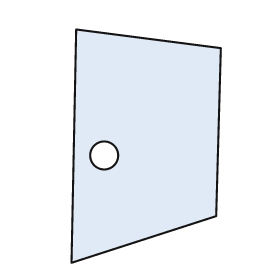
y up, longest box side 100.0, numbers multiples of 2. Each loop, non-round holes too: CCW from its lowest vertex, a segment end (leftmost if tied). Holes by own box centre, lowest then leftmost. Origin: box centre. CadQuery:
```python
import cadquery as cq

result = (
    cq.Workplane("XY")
    .moveTo(-32.0, -50.0)
    .lineTo(30.0, -30.0)
    .lineTo(32.0, 42.0)
    .lineTo(-30.0, 50.0)
    .close()
    .moveTo(-18.0, -4.0)
    .circle(6.0)
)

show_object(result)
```